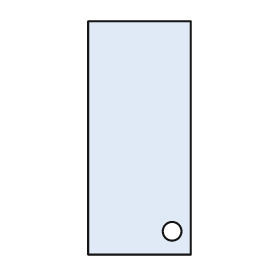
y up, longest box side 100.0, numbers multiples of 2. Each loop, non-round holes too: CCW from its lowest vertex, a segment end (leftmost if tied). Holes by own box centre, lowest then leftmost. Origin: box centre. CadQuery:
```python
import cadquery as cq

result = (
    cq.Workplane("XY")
    .moveTo(-22.0, -50.0)
    .lineTo(22.0, -50.0)
    .lineTo(22.0, 50.0)
    .lineTo(-22.0, 50.0)
    .close()
    .moveTo(14.0, -40.0)
    .circle(4.0)
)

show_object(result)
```